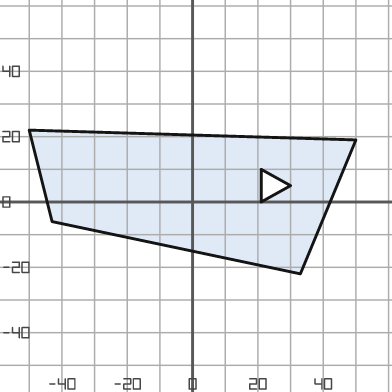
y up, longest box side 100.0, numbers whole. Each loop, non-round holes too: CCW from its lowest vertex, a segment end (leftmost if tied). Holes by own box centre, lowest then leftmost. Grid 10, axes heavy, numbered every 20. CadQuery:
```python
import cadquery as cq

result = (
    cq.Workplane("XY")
    .moveTo(33.0, -22.0)
    .lineTo(50.0, 19.0)
    .lineTo(-50.0, 22.0)
    .lineTo(-43.0, -6.0)
    .close()
    .moveTo(21.0, 0.0)
    .lineTo(30.0, 5.0)
    .lineTo(21.0, 10.0)
    .close()
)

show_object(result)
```